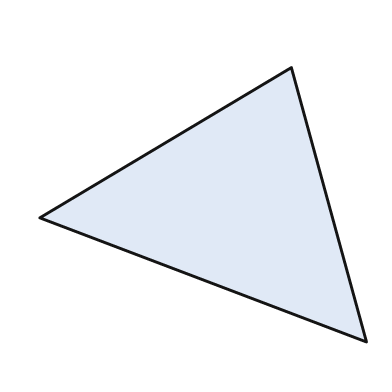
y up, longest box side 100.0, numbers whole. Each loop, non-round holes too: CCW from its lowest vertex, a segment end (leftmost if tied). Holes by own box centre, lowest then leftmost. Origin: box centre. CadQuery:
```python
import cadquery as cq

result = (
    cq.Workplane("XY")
    .moveTo(50.0, -42.0)
    .lineTo(27.0, 42.0)
    .lineTo(-50.0, -4.0)
    .close()
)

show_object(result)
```